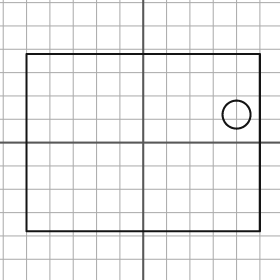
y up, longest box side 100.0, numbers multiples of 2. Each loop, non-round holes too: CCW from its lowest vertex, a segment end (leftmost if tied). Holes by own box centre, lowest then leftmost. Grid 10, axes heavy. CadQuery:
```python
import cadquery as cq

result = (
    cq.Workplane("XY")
    .moveTo(-50.0, -38.0)
    .lineTo(50.0, -38.0)
    .lineTo(50.0, 38.0)
    .lineTo(-50.0, 38.0)
    .close()
    .moveTo(40.0, 12.0)
    .circle(6.0)
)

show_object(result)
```